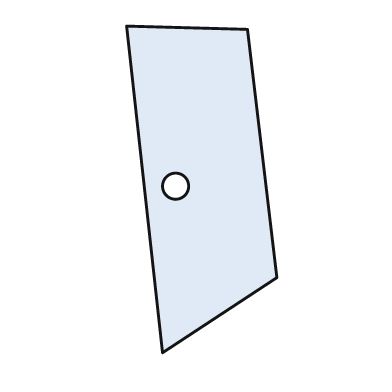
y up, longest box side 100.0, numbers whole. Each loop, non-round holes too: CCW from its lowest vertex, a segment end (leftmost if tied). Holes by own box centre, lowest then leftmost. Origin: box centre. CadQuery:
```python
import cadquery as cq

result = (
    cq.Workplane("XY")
    .moveTo(-12.0, -50.0)
    .lineTo(23.0, -27.0)
    .lineTo(14.0, 49.0)
    .lineTo(-23.0, 50.0)
    .close()
    .moveTo(-8.0, 1.0)
    .circle(4.0)
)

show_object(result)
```